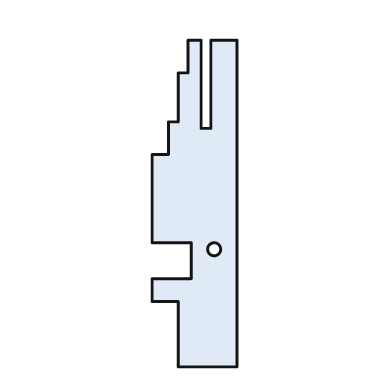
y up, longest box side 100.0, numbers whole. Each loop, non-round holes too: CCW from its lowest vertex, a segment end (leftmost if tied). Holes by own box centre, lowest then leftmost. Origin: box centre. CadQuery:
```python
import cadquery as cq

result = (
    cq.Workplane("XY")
    .moveTo(-5.0, -50.0)
    .lineTo(13.0, -50.0)
    .lineTo(13.0, 50.0)
    .lineTo(5.0, 50.0)
    .lineTo(5.0, 23.0)
    .lineTo(2.0, 23.0)
    .lineTo(2.0, 50.0)
    .lineTo(-2.0, 50.0)
    .lineTo(-2.0, 40.0)
    .lineTo(-5.0, 40.0)
    .lineTo(-5.0, 25.0)
    .lineTo(-8.0, 25.0)
    .lineTo(-8.0, 15.0)
    .lineTo(-13.0, 15.0)
    .lineTo(-13.0, -12.0)
    .lineTo(-1.0, -12.0)
    .lineTo(-1.0, -23.0)
    .lineTo(-13.0, -23.0)
    .lineTo(-13.0, -30.0)
    .lineTo(-5.0, -30.0)
    .close()
    .moveTo(6.0, -14.0)
    .circle(2.0)
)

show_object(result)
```